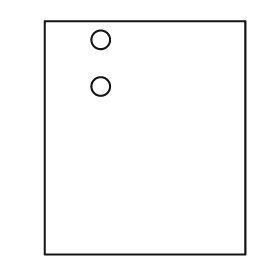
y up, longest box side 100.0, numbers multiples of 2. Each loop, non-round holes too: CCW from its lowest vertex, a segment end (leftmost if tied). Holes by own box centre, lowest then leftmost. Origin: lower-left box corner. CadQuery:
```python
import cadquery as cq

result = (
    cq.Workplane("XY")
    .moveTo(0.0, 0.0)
    .lineTo(86.0, 0.0)
    .lineTo(86.0, 100.0)
    .lineTo(0.0, 100.0)
    .close()
    .moveTo(24.0, 72.0)
    .circle(4.0)
    .moveTo(24.0, 92.0)
    .circle(4.0)
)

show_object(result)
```